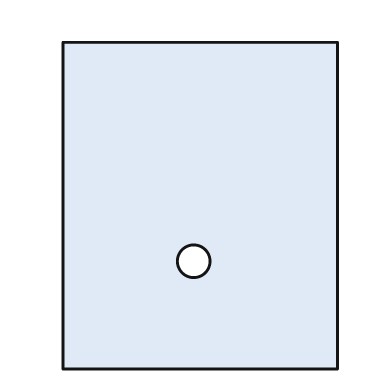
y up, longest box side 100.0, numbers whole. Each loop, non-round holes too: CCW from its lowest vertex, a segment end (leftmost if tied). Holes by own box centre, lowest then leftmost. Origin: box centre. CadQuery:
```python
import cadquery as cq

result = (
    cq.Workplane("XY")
    .moveTo(-42.0, -50.0)
    .lineTo(42.0, -50.0)
    .lineTo(42.0, 50.0)
    .lineTo(-42.0, 50.0)
    .close()
    .moveTo(-2.0, -17.0)
    .circle(5.0)
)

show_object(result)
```